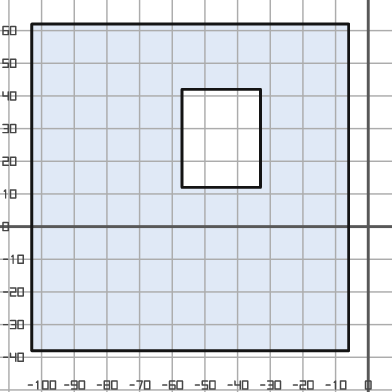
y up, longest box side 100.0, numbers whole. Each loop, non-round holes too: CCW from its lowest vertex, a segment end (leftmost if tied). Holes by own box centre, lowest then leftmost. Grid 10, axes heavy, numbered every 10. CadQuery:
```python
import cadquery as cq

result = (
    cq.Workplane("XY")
    .moveTo(-103.0, -38.0)
    .lineTo(-6.0, -38.0)
    .lineTo(-6.0, 62.0)
    .lineTo(-103.0, 62.0)
    .close()
    .moveTo(-57.0, 12.0)
    .lineTo(-33.0, 12.0)
    .lineTo(-33.0, 42.0)
    .lineTo(-57.0, 42.0)
    .close()
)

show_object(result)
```